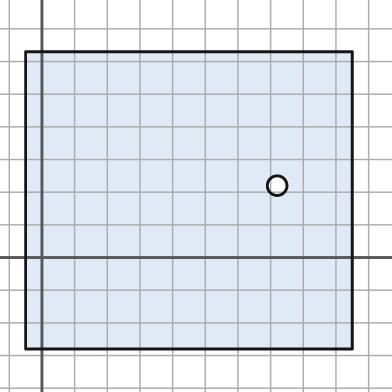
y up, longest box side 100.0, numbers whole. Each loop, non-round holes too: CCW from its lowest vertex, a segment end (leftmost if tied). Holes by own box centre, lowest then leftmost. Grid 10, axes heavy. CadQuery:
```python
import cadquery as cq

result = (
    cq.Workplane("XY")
    .moveTo(-5.0, -28.0)
    .lineTo(95.0, -28.0)
    .lineTo(95.0, 63.0)
    .lineTo(-5.0, 63.0)
    .close()
    .moveTo(72.0, 22.0)
    .circle(3.0)
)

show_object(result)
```